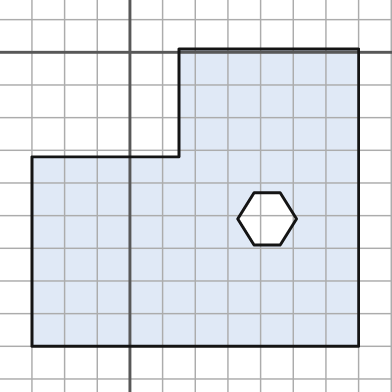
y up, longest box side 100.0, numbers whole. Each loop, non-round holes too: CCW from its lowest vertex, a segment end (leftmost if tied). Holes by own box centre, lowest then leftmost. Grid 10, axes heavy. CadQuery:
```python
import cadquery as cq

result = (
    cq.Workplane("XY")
    .moveTo(-30.0, -90.0)
    .lineTo(70.0, -90.0)
    .lineTo(70.0, 1.0)
    .lineTo(15.0, 1.0)
    .lineTo(15.0, -32.0)
    .lineTo(-30.0, -32.0)
    .close()
    .moveTo(38.0, -59.0)
    .lineTo(46.0, -59.0)
    .lineTo(51.0, -51.0)
    .lineTo(46.0, -43.0)
    .lineTo(38.0, -43.0)
    .lineTo(33.0, -51.0)
    .close()
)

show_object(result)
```